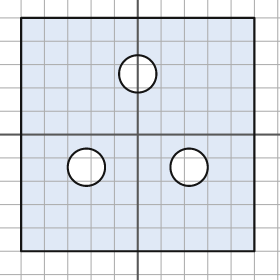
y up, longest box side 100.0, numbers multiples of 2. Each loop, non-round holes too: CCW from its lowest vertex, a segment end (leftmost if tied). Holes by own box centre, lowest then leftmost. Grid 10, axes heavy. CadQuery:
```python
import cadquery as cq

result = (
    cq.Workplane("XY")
    .moveTo(-50.0, -50.0)
    .lineTo(50.0, -50.0)
    .lineTo(50.0, 50.0)
    .lineTo(-50.0, 50.0)
    .close()
    .moveTo(-22.0, -14.0)
    .circle(8.0)
    .moveTo(22.0, -14.0)
    .circle(8.0)
    .moveTo(0.0, 26.0)
    .circle(8.0)
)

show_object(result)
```